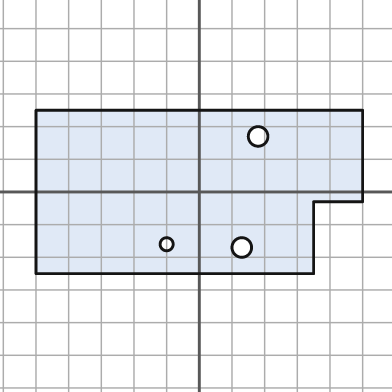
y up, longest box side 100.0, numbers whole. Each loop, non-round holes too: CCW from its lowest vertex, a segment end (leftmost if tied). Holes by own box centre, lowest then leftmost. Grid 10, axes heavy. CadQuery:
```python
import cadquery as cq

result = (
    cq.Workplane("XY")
    .moveTo(-50.0, -25.0)
    .lineTo(35.0, -25.0)
    .lineTo(35.0, -3.0)
    .lineTo(50.0, -3.0)
    .lineTo(50.0, 25.0)
    .lineTo(-50.0, 25.0)
    .close()
    .moveTo(13.0, -17.0)
    .circle(3.0)
    .moveTo(-10.0, -16.0)
    .circle(2.0)
    .moveTo(18.0, 17.0)
    .circle(3.0)
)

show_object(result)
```